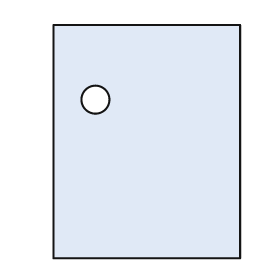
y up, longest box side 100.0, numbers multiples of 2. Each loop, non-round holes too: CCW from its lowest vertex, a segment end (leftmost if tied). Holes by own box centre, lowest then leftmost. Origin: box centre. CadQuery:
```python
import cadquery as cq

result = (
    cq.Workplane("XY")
    .moveTo(-40.0, -50.0)
    .lineTo(40.0, -50.0)
    .lineTo(40.0, 50.0)
    .lineTo(-40.0, 50.0)
    .close()
    .moveTo(-22.0, 18.0)
    .circle(6.0)
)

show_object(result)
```